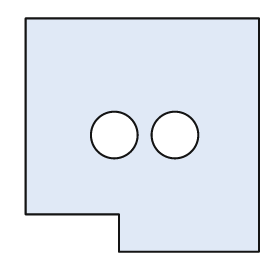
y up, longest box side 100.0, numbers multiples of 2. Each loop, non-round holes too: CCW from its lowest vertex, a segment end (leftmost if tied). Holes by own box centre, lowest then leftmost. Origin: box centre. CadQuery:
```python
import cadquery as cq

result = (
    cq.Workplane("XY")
    .moveTo(-10.0, -50.0)
    .lineTo(50.0, -50.0)
    .lineTo(50.0, 50.0)
    .lineTo(-50.0, 50.0)
    .lineTo(-50.0, -34.0)
    .lineTo(-10.0, -34.0)
    .close()
    .moveTo(-12.0, 0.0)
    .circle(10.0)
    .moveTo(14.0, 0.0)
    .circle(10.0)
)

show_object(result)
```